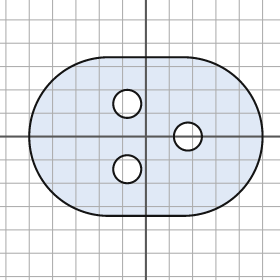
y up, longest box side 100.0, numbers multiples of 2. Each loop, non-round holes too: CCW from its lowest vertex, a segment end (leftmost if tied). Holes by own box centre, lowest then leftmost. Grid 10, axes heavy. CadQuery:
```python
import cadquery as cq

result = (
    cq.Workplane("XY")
    .moveTo(-16.0, -34.0)
    .lineTo(16.0, -34.0)
    .threePointArc((50.0, 0.0), (16.0, 34.0))
    .lineTo(-16.0, 34.0)
    .threePointArc((-50.0, 0.0), (-16.0, -34.0))
    .close()
    .moveTo(-8.0, -14.0)
    .circle(6.0)
    .moveTo(18.0, 0.0)
    .circle(6.0)
    .moveTo(-8.0, 14.0)
    .circle(6.0)
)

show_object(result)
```